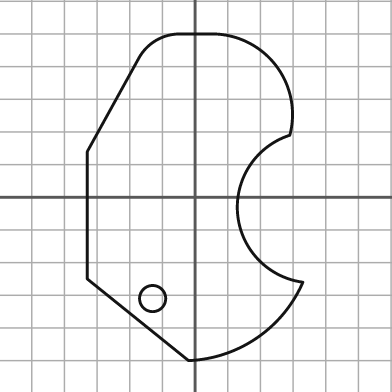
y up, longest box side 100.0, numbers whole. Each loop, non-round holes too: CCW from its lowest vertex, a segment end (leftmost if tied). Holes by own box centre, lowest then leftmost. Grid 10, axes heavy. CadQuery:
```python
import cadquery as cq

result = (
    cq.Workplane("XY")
    .moveTo(-2.0, -50.0)
    .threePointArc((19.0, -43.0), (33.0, -26.0))
    .threePointArc((13.0, -5.0), (29.0, 19.0))
    .threePointArc((25.0, 40.0), (6.0, 50.0))
    .lineTo(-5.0, 50.0)
    .threePointArc((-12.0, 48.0), (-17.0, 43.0))
    .lineTo(-33.0, 14.0)
    .lineTo(-33.0, -25.0)
    .close()
    .moveTo(-13.0, -31.0)
    .circle(4.0)
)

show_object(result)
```